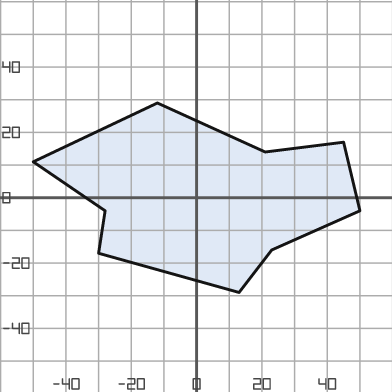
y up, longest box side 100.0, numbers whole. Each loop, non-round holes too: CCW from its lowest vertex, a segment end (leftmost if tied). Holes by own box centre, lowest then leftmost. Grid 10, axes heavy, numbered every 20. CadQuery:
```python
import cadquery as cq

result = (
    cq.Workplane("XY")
    .moveTo(13.0, -29.0)
    .lineTo(23.0, -16.0)
    .lineTo(50.0, -4.0)
    .lineTo(45.0, 17.0)
    .lineTo(21.0, 14.0)
    .lineTo(-12.0, 29.0)
    .lineTo(-50.0, 11.0)
    .lineTo(-28.0, -4.0)
    .lineTo(-30.0, -17.0)
    .close()
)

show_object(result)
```